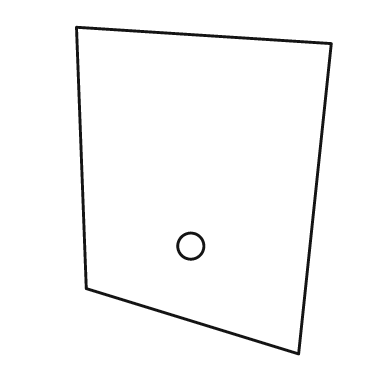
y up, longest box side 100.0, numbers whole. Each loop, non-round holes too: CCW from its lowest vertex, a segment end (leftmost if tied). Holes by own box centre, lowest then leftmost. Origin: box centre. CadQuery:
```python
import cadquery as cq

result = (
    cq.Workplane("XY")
    .moveTo(29.0, -50.0)
    .lineTo(39.0, 45.0)
    .lineTo(-39.0, 50.0)
    .lineTo(-36.0, -30.0)
    .close()
    .moveTo(-4.0, -17.0)
    .circle(4.0)
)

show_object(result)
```